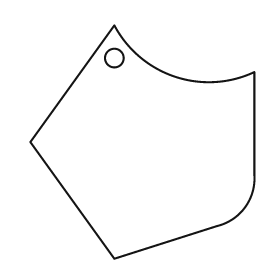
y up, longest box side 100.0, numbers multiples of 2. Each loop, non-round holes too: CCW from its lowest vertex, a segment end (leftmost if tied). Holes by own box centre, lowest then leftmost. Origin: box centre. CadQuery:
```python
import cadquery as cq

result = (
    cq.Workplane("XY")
    .moveTo(-12.0, -50.0)
    .lineTo(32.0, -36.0)
    .threePointArc((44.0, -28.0), (48.0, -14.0))
    .lineTo(48.0, 30.0)
    .threePointArc((14.0, 28.0), (-12.0, 50.0))
    .lineTo(-48.0, 0.0)
    .close()
    .moveTo(-12.0, 36.0)
    .circle(4.0)
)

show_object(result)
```